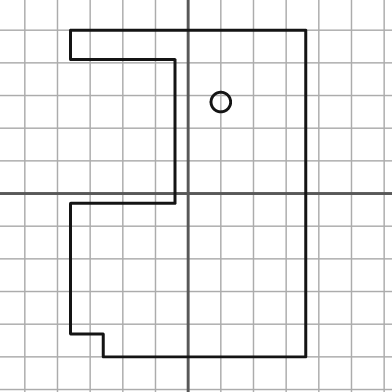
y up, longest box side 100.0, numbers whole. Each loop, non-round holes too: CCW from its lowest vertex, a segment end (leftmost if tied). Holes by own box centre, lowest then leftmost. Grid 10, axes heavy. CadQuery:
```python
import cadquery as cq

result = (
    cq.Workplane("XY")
    .moveTo(-26.0, -50.0)
    .lineTo(36.0, -50.0)
    .lineTo(36.0, 50.0)
    .lineTo(-36.0, 50.0)
    .lineTo(-36.0, 41.0)
    .lineTo(-4.0, 41.0)
    .lineTo(-4.0, -3.0)
    .lineTo(-36.0, -3.0)
    .lineTo(-36.0, -43.0)
    .lineTo(-26.0, -43.0)
    .close()
    .moveTo(10.0, 28.0)
    .circle(3.0)
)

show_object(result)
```